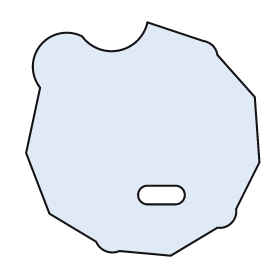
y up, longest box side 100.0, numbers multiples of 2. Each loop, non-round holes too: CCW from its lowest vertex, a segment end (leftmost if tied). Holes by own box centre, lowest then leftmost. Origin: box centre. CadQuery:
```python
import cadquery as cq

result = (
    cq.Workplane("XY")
    .moveTo(12.0, -50.0)
    .lineTo(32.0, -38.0)
    .threePointArc((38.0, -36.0), (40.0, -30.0))
    .lineTo(50.0, -10.0)
    .lineTo(48.0, 18.0)
    .lineTo(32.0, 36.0)
    .threePointArc((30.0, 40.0), (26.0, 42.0))
    .lineTo(2.0, 50.0)
    .threePointArc((-10.0, 38.0), (-26.0, 44.0))
    .threePointArc((-44.0, 40.0), (-44.0, 22.0))
    .lineTo(-50.0, -6.0)
    .lineTo(-40.0, -32.0)
    .lineTo(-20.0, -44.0)
    .threePointArc((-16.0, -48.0), (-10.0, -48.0))
    .close()
    .moveTo(2.0, -28.0)
    .lineTo(14.0, -28.0)
    .threePointArc((18.0, -24.0), (14.0, -20.0))
    .lineTo(2.0, -20.0)
    .threePointArc((-2.0, -24.0), (2.0, -28.0))
    .close()
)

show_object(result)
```